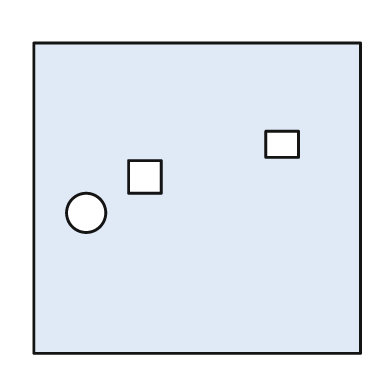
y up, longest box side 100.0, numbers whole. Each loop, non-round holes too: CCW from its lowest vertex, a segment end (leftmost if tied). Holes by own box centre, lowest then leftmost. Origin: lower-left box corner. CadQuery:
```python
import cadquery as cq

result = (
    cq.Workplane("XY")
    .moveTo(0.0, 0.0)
    .lineTo(100.0, 0.0)
    .lineTo(100.0, 95.0)
    .lineTo(0.0, 95.0)
    .close()
    .moveTo(16.0, 43.0)
    .circle(6.0)
    .moveTo(29.0, 49.0)
    .lineTo(39.0, 49.0)
    .lineTo(39.0, 59.0)
    .lineTo(29.0, 59.0)
    .close()
    .moveTo(71.0, 60.0)
    .lineTo(81.0, 60.0)
    .lineTo(81.0, 68.0)
    .lineTo(71.0, 68.0)
    .close()
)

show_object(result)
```